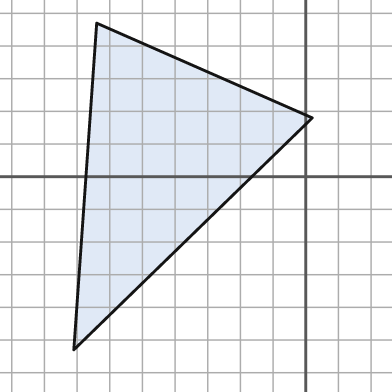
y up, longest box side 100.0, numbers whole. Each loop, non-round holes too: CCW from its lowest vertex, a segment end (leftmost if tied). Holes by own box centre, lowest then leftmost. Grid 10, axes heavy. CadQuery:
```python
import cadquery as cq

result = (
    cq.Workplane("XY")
    .moveTo(-71.0, -53.0)
    .lineTo(2.0, 18.0)
    .lineTo(-64.0, 47.0)
    .close()
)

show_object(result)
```